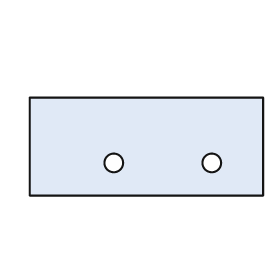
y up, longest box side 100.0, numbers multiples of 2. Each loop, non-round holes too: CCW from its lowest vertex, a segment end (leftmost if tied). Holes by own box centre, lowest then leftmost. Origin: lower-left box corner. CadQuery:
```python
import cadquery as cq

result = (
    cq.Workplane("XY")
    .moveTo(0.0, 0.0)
    .lineTo(100.0, 0.0)
    .lineTo(100.0, 42.0)
    .lineTo(0.0, 42.0)
    .close()
    .moveTo(36.0, 14.0)
    .circle(4.0)
    .moveTo(78.0, 14.0)
    .circle(4.0)
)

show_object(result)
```